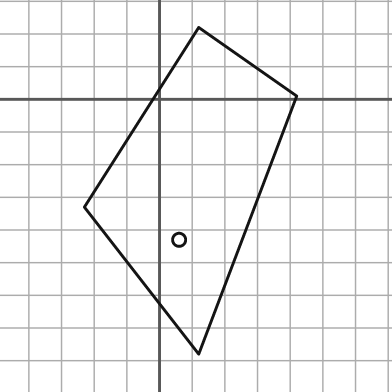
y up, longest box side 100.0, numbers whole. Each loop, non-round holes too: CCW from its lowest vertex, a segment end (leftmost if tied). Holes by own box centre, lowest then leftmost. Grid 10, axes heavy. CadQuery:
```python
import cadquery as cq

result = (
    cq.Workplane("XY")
    .moveTo(12.0, -78.0)
    .lineTo(42.0, 1.0)
    .lineTo(12.0, 22.0)
    .lineTo(-23.0, -33.0)
    .close()
    .moveTo(6.0, -43.0)
    .circle(2.0)
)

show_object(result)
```